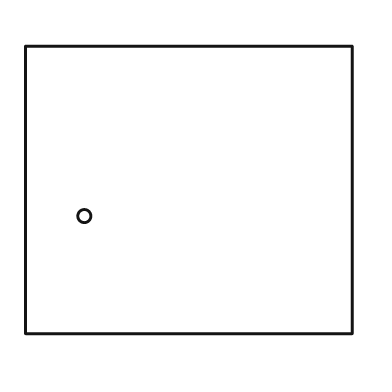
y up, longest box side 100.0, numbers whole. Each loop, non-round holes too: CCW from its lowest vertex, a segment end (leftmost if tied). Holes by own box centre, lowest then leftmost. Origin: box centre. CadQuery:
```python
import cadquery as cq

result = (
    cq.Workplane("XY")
    .moveTo(-50.0, -44.0)
    .lineTo(50.0, -44.0)
    .lineTo(50.0, 44.0)
    .lineTo(-50.0, 44.0)
    .close()
    .moveTo(-32.0, -8.0)
    .circle(2.0)
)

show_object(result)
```